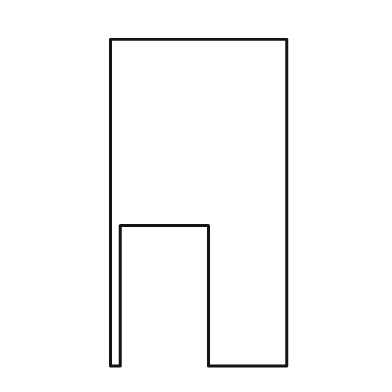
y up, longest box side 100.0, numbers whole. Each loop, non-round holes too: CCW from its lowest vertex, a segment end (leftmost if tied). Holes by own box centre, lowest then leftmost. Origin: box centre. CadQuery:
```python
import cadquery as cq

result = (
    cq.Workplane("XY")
    .moveTo(-27.0, -50.0)
    .lineTo(-24.0, -50.0)
    .lineTo(-24.0, -7.0)
    .lineTo(3.0, -7.0)
    .lineTo(3.0, -50.0)
    .lineTo(27.0, -50.0)
    .lineTo(27.0, 50.0)
    .lineTo(-27.0, 50.0)
    .close()
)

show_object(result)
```